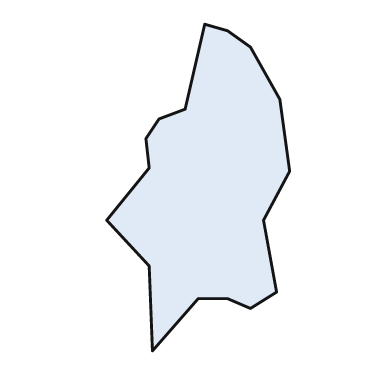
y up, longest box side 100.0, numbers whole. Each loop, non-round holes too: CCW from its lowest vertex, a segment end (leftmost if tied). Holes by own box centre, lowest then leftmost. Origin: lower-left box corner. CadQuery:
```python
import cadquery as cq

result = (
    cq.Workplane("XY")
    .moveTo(14.0, 0.0)
    .lineTo(28.0, 16.0)
    .lineTo(37.0, 16.0)
    .lineTo(44.0, 13.0)
    .lineTo(52.0, 18.0)
    .lineTo(48.0, 40.0)
    .lineTo(56.0, 55.0)
    .lineTo(53.0, 77.0)
    .lineTo(44.0, 93.0)
    .lineTo(37.0, 98.0)
    .lineTo(30.0, 100.0)
    .lineTo(24.0, 74.0)
    .lineTo(16.0, 71.0)
    .lineTo(12.0, 65.0)
    .lineTo(13.0, 56.0)
    .lineTo(0.0, 40.0)
    .lineTo(13.0, 26.0)
    .close()
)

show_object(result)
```